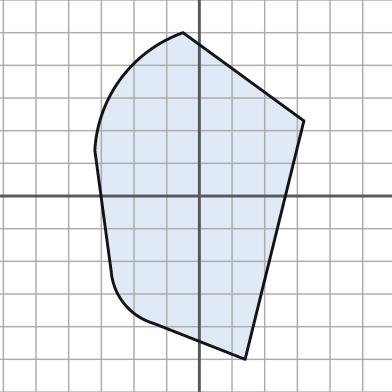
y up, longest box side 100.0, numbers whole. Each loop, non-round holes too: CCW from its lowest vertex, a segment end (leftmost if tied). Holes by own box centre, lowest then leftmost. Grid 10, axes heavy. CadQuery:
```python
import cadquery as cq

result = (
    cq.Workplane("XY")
    .moveTo(14.0, -50.0)
    .lineTo(32.0, 23.0)
    .lineTo(-5.0, 50.0)
    .threePointArc((-24.0, 36.0), (-32.0, 14.0))
    .lineTo(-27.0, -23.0)
    .threePointArc((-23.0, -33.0), (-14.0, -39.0))
    .close()
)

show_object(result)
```